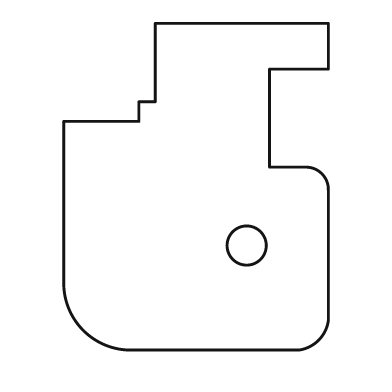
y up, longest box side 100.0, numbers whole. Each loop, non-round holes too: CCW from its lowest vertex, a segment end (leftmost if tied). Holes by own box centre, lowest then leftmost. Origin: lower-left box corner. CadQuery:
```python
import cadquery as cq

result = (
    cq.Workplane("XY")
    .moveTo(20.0, 0.0)
    .lineTo(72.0, 0.0)
    .threePointArc((78.0, 3.0), (81.0, 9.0))
    .lineTo(81.0, 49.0)
    .threePointArc((79.0, 54.0), (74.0, 56.0))
    .lineTo(63.0, 56.0)
    .lineTo(63.0, 86.0)
    .lineTo(81.0, 86.0)
    .lineTo(81.0, 100.0)
    .lineTo(28.0, 100.0)
    .lineTo(28.0, 76.0)
    .lineTo(23.0, 76.0)
    .lineTo(23.0, 70.0)
    .lineTo(0.0, 70.0)
    .lineTo(0.0, 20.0)
    .threePointArc((6.0, 6.0), (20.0, 0.0))
    .close()
    .moveTo(56.0, 32.0)
    .circle(6.0)
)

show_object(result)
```